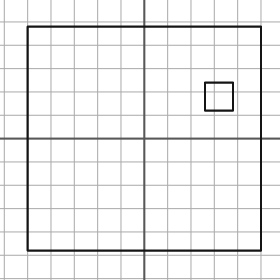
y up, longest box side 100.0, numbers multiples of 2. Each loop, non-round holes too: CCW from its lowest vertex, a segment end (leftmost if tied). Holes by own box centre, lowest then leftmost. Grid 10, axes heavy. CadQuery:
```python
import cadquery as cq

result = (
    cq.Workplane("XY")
    .moveTo(-50.0, -48.0)
    .lineTo(50.0, -48.0)
    .lineTo(50.0, 48.0)
    .lineTo(-50.0, 48.0)
    .close()
    .moveTo(26.0, 12.0)
    .lineTo(38.0, 12.0)
    .lineTo(38.0, 24.0)
    .lineTo(26.0, 24.0)
    .close()
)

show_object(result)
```